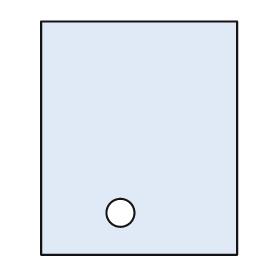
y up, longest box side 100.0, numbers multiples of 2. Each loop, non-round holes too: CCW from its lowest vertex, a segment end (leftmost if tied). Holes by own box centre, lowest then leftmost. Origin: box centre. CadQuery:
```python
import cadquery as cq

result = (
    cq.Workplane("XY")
    .moveTo(-42.0, -50.0)
    .lineTo(42.0, -50.0)
    .lineTo(42.0, 50.0)
    .lineTo(-42.0, 50.0)
    .close()
    .moveTo(-8.0, -32.0)
    .circle(6.0)
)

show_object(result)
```